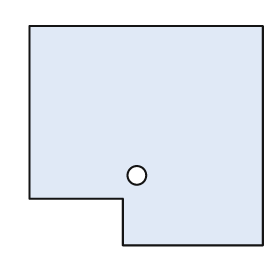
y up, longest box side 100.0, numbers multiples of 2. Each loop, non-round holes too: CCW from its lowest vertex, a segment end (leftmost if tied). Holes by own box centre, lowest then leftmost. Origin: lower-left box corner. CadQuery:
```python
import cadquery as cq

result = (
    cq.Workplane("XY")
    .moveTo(40.0, 0.0)
    .lineTo(100.0, 0.0)
    .lineTo(100.0, 94.0)
    .lineTo(0.0, 94.0)
    .lineTo(0.0, 20.0)
    .lineTo(40.0, 20.0)
    .close()
    .moveTo(46.0, 30.0)
    .circle(4.0)
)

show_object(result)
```